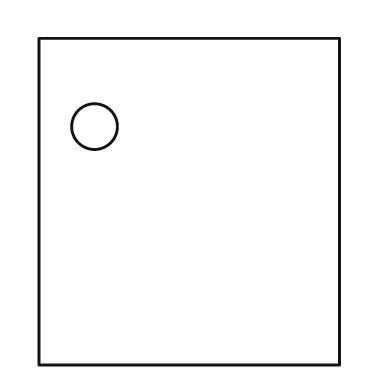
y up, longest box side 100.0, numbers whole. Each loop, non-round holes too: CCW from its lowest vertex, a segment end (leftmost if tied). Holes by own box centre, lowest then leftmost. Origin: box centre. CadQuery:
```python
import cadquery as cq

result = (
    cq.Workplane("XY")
    .moveTo(-46.0, -50.0)
    .lineTo(46.0, -50.0)
    .lineTo(46.0, 50.0)
    .lineTo(-46.0, 50.0)
    .close()
    .moveTo(-29.0, 23.0)
    .circle(7.0)
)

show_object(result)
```